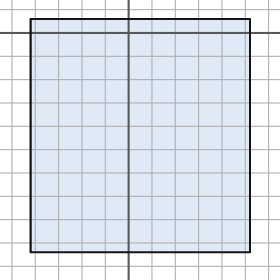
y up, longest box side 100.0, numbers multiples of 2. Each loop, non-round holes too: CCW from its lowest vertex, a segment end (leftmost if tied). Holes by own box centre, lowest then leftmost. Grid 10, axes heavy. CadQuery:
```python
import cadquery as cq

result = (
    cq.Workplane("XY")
    .moveTo(-42.0, -94.0)
    .lineTo(52.0, -94.0)
    .lineTo(52.0, 6.0)
    .lineTo(-42.0, 6.0)
    .close()
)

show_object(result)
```